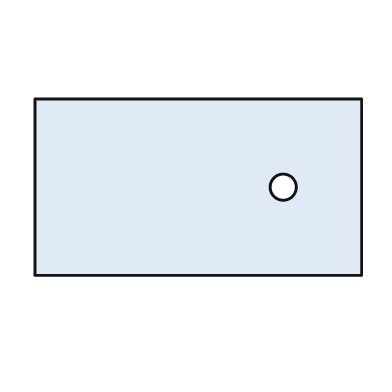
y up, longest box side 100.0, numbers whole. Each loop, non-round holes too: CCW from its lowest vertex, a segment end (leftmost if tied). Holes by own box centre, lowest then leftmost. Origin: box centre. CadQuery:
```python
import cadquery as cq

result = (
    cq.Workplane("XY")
    .moveTo(-50.0, -27.0)
    .lineTo(50.0, -27.0)
    .lineTo(50.0, 27.0)
    .lineTo(-50.0, 27.0)
    .close()
    .moveTo(26.0, 0.0)
    .circle(4.0)
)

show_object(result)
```